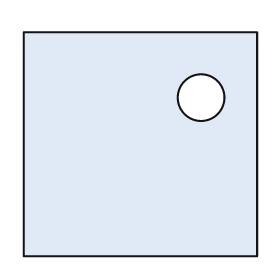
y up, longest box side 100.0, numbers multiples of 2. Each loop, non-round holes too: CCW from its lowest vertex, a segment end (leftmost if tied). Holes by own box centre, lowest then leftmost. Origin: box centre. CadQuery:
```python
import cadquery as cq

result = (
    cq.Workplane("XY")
    .moveTo(-50.0, -48.0)
    .lineTo(50.0, -48.0)
    .lineTo(50.0, 48.0)
    .lineTo(-50.0, 48.0)
    .close()
    .moveTo(26.0, 20.0)
    .circle(10.0)
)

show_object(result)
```